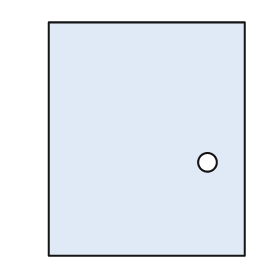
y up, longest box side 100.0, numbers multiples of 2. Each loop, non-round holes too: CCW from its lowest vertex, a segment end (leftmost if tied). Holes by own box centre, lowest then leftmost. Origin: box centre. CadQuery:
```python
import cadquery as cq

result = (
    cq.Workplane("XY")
    .moveTo(-42.0, -50.0)
    .lineTo(42.0, -50.0)
    .lineTo(42.0, 50.0)
    .lineTo(-42.0, 50.0)
    .close()
    .moveTo(26.0, -10.0)
    .circle(4.0)
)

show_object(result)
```